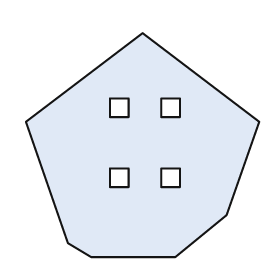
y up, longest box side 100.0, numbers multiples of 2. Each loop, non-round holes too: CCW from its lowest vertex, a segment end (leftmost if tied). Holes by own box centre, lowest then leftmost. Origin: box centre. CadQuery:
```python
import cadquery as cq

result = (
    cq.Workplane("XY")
    .moveTo(-22.0, -48.0)
    .lineTo(14.0, -48.0)
    .lineTo(36.0, -30.0)
    .lineTo(50.0, 10.0)
    .lineTo(0.0, 48.0)
    .lineTo(-50.0, 10.0)
    .lineTo(-32.0, -42.0)
    .close()
    .moveTo(-14.0, -18.0)
    .lineTo(-6.0, -18.0)
    .lineTo(-6.0, -10.0)
    .lineTo(-14.0, -10.0)
    .close()
    .moveTo(8.0, -18.0)
    .lineTo(16.0, -18.0)
    .lineTo(16.0, -10.0)
    .lineTo(8.0, -10.0)
    .close()
    .moveTo(-14.0, 12.0)
    .lineTo(-6.0, 12.0)
    .lineTo(-6.0, 20.0)
    .lineTo(-14.0, 20.0)
    .close()
    .moveTo(8.0, 12.0)
    .lineTo(16.0, 12.0)
    .lineTo(16.0, 20.0)
    .lineTo(8.0, 20.0)
    .close()
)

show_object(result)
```